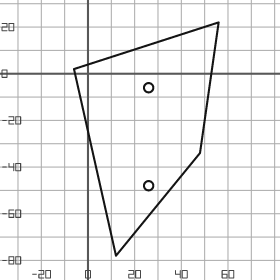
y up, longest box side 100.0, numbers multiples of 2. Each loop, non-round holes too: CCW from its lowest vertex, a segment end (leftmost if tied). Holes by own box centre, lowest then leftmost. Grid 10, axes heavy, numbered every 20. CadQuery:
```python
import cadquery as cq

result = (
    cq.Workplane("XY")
    .moveTo(12.0, -78.0)
    .lineTo(48.0, -34.0)
    .lineTo(56.0, 22.0)
    .lineTo(-6.0, 2.0)
    .close()
    .moveTo(26.0, -48.0)
    .circle(2.0)
    .moveTo(26.0, -6.0)
    .circle(2.0)
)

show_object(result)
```